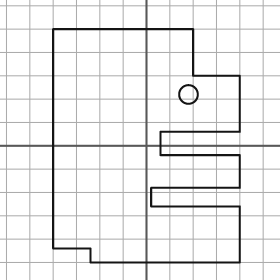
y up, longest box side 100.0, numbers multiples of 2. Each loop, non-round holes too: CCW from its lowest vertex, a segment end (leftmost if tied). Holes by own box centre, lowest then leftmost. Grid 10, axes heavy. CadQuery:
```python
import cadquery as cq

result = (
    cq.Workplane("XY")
    .moveTo(-24.0, -50.0)
    .lineTo(40.0, -50.0)
    .lineTo(40.0, -26.0)
    .lineTo(2.0, -26.0)
    .lineTo(2.0, -18.0)
    .lineTo(40.0, -18.0)
    .lineTo(40.0, -4.0)
    .lineTo(6.0, -4.0)
    .lineTo(6.0, 6.0)
    .lineTo(40.0, 6.0)
    .lineTo(40.0, 30.0)
    .lineTo(20.0, 30.0)
    .lineTo(20.0, 50.0)
    .lineTo(-40.0, 50.0)
    .lineTo(-40.0, -44.0)
    .lineTo(-24.0, -44.0)
    .close()
    .moveTo(18.0, 22.0)
    .circle(4.0)
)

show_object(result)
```